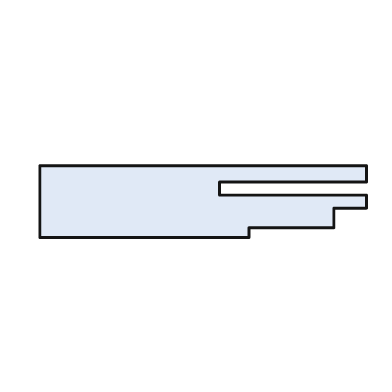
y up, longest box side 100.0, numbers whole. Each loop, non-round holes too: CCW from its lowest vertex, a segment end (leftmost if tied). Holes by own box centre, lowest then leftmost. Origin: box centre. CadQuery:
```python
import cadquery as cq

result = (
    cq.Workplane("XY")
    .moveTo(-50.0, -11.0)
    .lineTo(14.0, -11.0)
    .lineTo(14.0, -8.0)
    .lineTo(40.0, -8.0)
    .lineTo(40.0, -2.0)
    .lineTo(50.0, -2.0)
    .lineTo(50.0, 2.0)
    .lineTo(5.0, 2.0)
    .lineTo(5.0, 6.0)
    .lineTo(50.0, 6.0)
    .lineTo(50.0, 11.0)
    .lineTo(-50.0, 11.0)
    .close()
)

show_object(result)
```